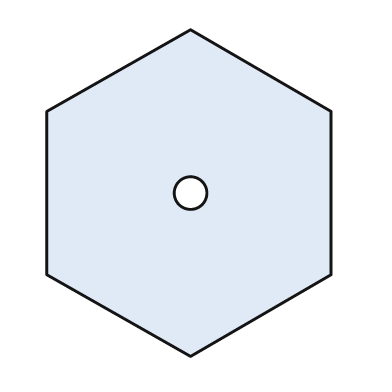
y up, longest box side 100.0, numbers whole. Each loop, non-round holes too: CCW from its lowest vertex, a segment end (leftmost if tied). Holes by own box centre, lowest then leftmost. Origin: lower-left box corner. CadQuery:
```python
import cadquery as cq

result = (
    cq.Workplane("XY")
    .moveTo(44.0, 0.0)
    .lineTo(87.0, 25.0)
    .lineTo(87.0, 75.0)
    .lineTo(44.0, 100.0)
    .lineTo(0.0, 75.0)
    .lineTo(0.0, 25.0)
    .close()
    .moveTo(44.0, 50.0)
    .circle(5.0)
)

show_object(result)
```